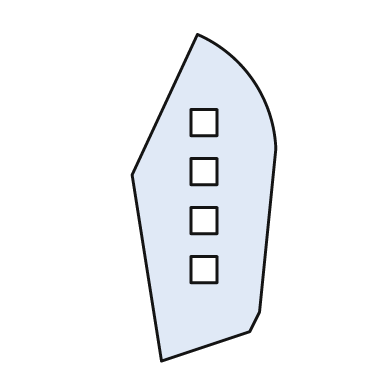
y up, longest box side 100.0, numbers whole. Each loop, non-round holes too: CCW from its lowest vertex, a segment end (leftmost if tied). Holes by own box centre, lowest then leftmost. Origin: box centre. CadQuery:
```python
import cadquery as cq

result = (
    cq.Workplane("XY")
    .moveTo(-13.0, -50.0)
    .lineTo(14.0, -41.0)
    .lineTo(17.0, -35.0)
    .lineTo(22.0, 15.0)
    .threePointArc((15.0, 36.0), (-2.0, 50.0))
    .lineTo(-22.0, 7.0)
    .close()
    .moveTo(-4.0, -26.0)
    .lineTo(4.0, -26.0)
    .lineTo(4.0, -18.0)
    .lineTo(-4.0, -18.0)
    .close()
    .moveTo(-4.0, -11.0)
    .lineTo(4.0, -11.0)
    .lineTo(4.0, -3.0)
    .lineTo(-4.0, -3.0)
    .close()
    .moveTo(-4.0, 4.0)
    .lineTo(4.0, 4.0)
    .lineTo(4.0, 12.0)
    .lineTo(-4.0, 12.0)
    .close()
    .moveTo(-4.0, 19.0)
    .lineTo(4.0, 19.0)
    .lineTo(4.0, 27.0)
    .lineTo(-4.0, 27.0)
    .close()
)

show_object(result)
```